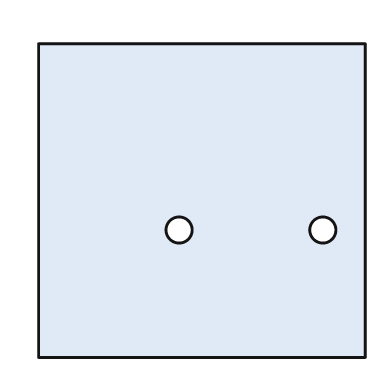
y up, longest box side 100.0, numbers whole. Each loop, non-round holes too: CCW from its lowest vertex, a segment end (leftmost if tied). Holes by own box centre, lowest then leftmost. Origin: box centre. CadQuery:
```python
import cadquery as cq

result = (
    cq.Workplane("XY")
    .moveTo(-50.0, -48.0)
    .lineTo(50.0, -48.0)
    .lineTo(50.0, 48.0)
    .lineTo(-50.0, 48.0)
    .close()
    .moveTo(-7.0, -9.0)
    .circle(4.0)
    .moveTo(37.0, -9.0)
    .circle(4.0)
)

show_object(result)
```